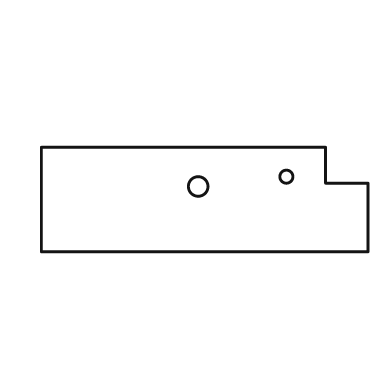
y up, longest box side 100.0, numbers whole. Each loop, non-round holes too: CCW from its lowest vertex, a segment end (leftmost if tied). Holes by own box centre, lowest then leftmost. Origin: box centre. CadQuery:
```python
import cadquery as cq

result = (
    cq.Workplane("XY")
    .moveTo(-50.0, -16.0)
    .lineTo(50.0, -16.0)
    .lineTo(50.0, 5.0)
    .lineTo(37.0, 5.0)
    .lineTo(37.0, 16.0)
    .lineTo(-50.0, 16.0)
    .close()
    .moveTo(-2.0, 4.0)
    .circle(3.0)
    .moveTo(25.0, 7.0)
    .circle(2.0)
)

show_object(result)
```